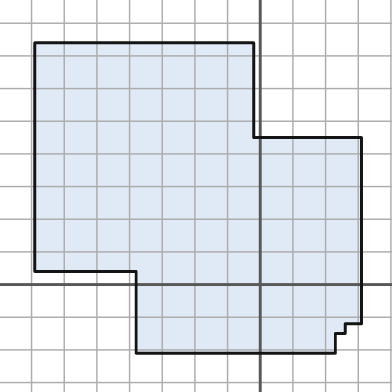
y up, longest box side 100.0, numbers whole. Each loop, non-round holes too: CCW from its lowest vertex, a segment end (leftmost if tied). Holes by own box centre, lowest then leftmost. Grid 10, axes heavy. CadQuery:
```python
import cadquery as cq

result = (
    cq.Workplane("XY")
    .moveTo(-38.0, -21.0)
    .lineTo(23.0, -21.0)
    .lineTo(23.0, -15.0)
    .lineTo(26.0, -15.0)
    .lineTo(26.0, -12.0)
    .lineTo(31.0, -12.0)
    .lineTo(31.0, 45.0)
    .lineTo(-2.0, 45.0)
    .lineTo(-2.0, 74.0)
    .lineTo(-69.0, 74.0)
    .lineTo(-69.0, 4.0)
    .lineTo(-38.0, 4.0)
    .close()
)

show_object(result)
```